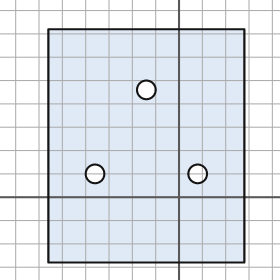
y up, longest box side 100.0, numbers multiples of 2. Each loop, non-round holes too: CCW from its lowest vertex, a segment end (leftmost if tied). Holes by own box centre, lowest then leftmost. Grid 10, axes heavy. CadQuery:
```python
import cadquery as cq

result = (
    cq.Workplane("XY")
    .moveTo(-56.0, -28.0)
    .lineTo(28.0, -28.0)
    .lineTo(28.0, 72.0)
    .lineTo(-56.0, 72.0)
    .close()
    .moveTo(-36.0, 10.0)
    .circle(4.0)
    .moveTo(8.0, 10.0)
    .circle(4.0)
    .moveTo(-14.0, 46.0)
    .circle(4.0)
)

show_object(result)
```